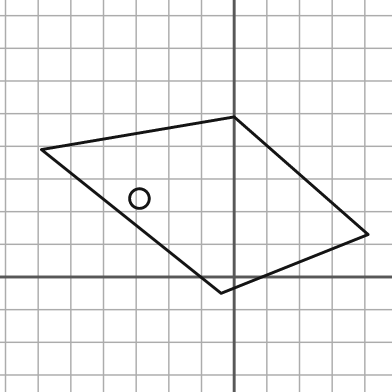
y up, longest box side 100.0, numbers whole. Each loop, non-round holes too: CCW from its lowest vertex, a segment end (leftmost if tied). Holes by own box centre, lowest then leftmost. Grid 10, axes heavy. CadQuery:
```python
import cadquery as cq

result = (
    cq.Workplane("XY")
    .moveTo(-4.0, -5.0)
    .lineTo(41.0, 13.0)
    .lineTo(0.0, 49.0)
    .lineTo(-59.0, 39.0)
    .close()
    .moveTo(-29.0, 24.0)
    .circle(3.0)
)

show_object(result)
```